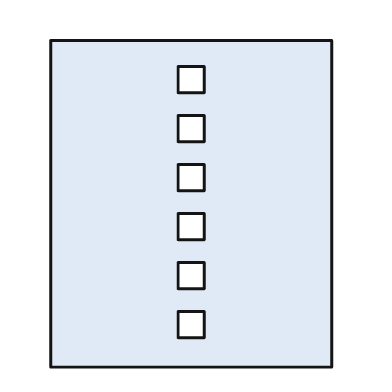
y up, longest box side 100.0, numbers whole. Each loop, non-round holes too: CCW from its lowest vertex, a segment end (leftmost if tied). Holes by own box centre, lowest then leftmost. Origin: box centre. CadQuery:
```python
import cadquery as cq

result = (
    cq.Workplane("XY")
    .moveTo(-43.0, -50.0)
    .lineTo(43.0, -50.0)
    .lineTo(43.0, 50.0)
    .lineTo(-43.0, 50.0)
    .close()
    .moveTo(-4.0, -41.0)
    .lineTo(4.0, -41.0)
    .lineTo(4.0, -33.0)
    .lineTo(-4.0, -33.0)
    .close()
    .moveTo(-4.0, -26.0)
    .lineTo(4.0, -26.0)
    .lineTo(4.0, -18.0)
    .lineTo(-4.0, -18.0)
    .close()
    .moveTo(-4.0, -11.0)
    .lineTo(4.0, -11.0)
    .lineTo(4.0, -3.0)
    .lineTo(-4.0, -3.0)
    .close()
    .moveTo(-4.0, 4.0)
    .lineTo(4.0, 4.0)
    .lineTo(4.0, 12.0)
    .lineTo(-4.0, 12.0)
    .close()
    .moveTo(-4.0, 19.0)
    .lineTo(4.0, 19.0)
    .lineTo(4.0, 27.0)
    .lineTo(-4.0, 27.0)
    .close()
    .moveTo(-4.0, 34.0)
    .lineTo(4.0, 34.0)
    .lineTo(4.0, 42.0)
    .lineTo(-4.0, 42.0)
    .close()
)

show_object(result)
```